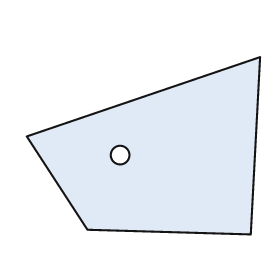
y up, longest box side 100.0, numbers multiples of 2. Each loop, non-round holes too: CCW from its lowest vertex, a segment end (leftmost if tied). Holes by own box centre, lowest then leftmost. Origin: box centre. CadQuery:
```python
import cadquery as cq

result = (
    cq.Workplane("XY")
    .moveTo(46.0, -38.0)
    .lineTo(50.0, 38.0)
    .lineTo(-50.0, 4.0)
    .lineTo(-24.0, -36.0)
    .close()
    .moveTo(-10.0, -4.0)
    .circle(4.0)
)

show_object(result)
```